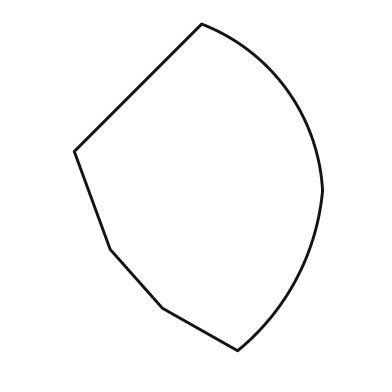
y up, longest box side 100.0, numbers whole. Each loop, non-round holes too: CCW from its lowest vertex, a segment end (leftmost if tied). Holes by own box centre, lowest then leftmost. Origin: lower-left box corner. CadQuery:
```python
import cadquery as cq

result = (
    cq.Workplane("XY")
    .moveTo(50.0, 0.0)
    .threePointArc((68.0, 22.0), (76.0, 49.0))
    .threePointArc((65.0, 80.0), (39.0, 100.0))
    .lineTo(0.0, 61.0)
    .lineTo(11.0, 31.0)
    .lineTo(27.0, 13.0)
    .close()
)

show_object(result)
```